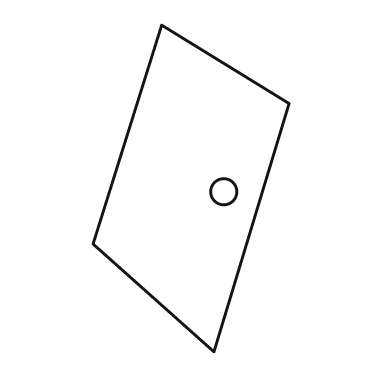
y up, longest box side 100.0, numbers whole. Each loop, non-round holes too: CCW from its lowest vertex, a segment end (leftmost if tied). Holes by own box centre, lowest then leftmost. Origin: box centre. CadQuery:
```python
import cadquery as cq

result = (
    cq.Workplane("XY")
    .moveTo(7.0, -50.0)
    .lineTo(30.0, 26.0)
    .lineTo(-9.0, 50.0)
    .lineTo(-30.0, -17.0)
    .close()
    .moveTo(10.0, -1.0)
    .circle(4.0)
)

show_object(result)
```